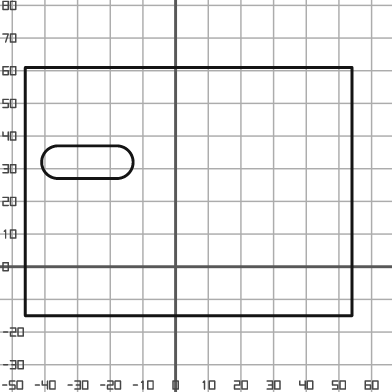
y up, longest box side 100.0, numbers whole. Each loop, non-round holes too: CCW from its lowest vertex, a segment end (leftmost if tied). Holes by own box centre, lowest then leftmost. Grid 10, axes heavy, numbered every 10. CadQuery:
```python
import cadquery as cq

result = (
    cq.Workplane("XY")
    .moveTo(-46.0, -15.0)
    .lineTo(54.0, -15.0)
    .lineTo(54.0, 61.0)
    .lineTo(-46.0, 61.0)
    .close()
    .moveTo(-36.0, 27.0)
    .lineTo(-18.0, 27.0)
    .threePointArc((-13.0, 32.0), (-18.0, 37.0))
    .lineTo(-36.0, 37.0)
    .threePointArc((-41.0, 32.0), (-36.0, 27.0))
    .close()
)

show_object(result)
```